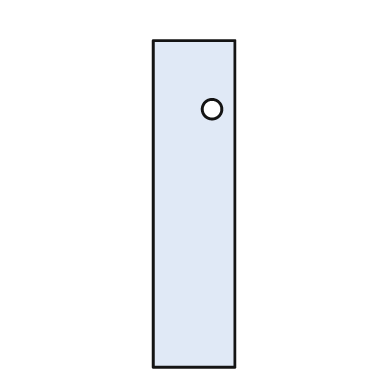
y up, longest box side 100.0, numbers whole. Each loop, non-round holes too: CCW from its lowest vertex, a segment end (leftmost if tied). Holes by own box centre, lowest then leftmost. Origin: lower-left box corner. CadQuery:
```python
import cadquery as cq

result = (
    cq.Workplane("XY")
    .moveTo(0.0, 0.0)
    .lineTo(25.0, 0.0)
    .lineTo(25.0, 100.0)
    .lineTo(0.0, 100.0)
    .close()
    .moveTo(18.0, 79.0)
    .circle(3.0)
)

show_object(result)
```